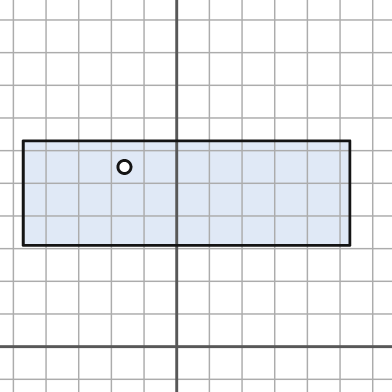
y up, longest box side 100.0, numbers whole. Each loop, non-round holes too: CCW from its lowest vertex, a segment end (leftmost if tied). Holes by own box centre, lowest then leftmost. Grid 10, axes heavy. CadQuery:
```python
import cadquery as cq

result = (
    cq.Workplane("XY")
    .moveTo(-47.0, 31.0)
    .lineTo(53.0, 31.0)
    .lineTo(53.0, 63.0)
    .lineTo(-47.0, 63.0)
    .close()
    .moveTo(-16.0, 55.0)
    .circle(2.0)
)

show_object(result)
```